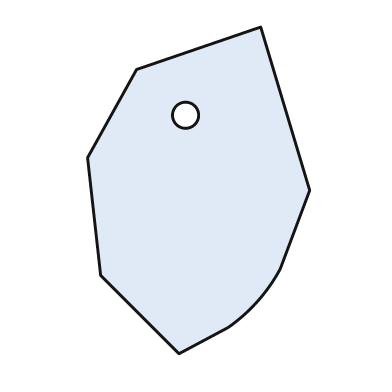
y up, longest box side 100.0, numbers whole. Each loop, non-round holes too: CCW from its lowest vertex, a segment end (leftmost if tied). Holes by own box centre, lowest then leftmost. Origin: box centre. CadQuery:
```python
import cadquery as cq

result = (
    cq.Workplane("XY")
    .moveTo(-6.0, -50.0)
    .lineTo(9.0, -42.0)
    .threePointArc((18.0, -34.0), (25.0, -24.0))
    .lineTo(34.0, 0.0)
    .lineTo(19.0, 50.0)
    .lineTo(-19.0, 37.0)
    .lineTo(-34.0, 10.0)
    .lineTo(-30.0, -26.0)
    .close()
    .moveTo(-4.0, 23.0)
    .circle(4.0)
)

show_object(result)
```